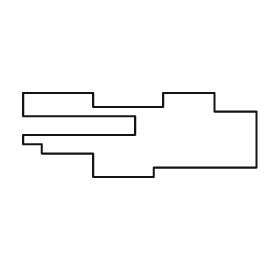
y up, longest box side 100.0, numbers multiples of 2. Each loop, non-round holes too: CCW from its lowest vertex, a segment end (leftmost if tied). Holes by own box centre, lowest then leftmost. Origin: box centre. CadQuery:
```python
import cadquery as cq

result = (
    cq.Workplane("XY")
    .moveTo(-20.0, -18.0)
    .lineTo(6.0, -18.0)
    .lineTo(6.0, -14.0)
    .lineTo(50.0, -14.0)
    .lineTo(50.0, 10.0)
    .lineTo(32.0, 10.0)
    .lineTo(32.0, 18.0)
    .lineTo(10.0, 18.0)
    .lineTo(10.0, 12.0)
    .lineTo(-20.0, 12.0)
    .lineTo(-20.0, 18.0)
    .lineTo(-50.0, 18.0)
    .lineTo(-50.0, 8.0)
    .lineTo(-2.0, 8.0)
    .lineTo(-2.0, 0.0)
    .lineTo(-50.0, 0.0)
    .lineTo(-50.0, -4.0)
    .lineTo(-42.0, -4.0)
    .lineTo(-42.0, -8.0)
    .lineTo(-20.0, -8.0)
    .close()
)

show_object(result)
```